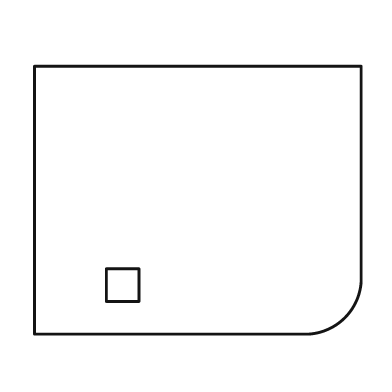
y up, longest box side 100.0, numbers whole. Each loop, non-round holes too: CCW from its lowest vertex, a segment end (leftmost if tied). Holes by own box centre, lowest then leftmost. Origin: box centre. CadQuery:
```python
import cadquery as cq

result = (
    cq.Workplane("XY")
    .moveTo(-50.0, -41.0)
    .lineTo(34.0, -41.0)
    .threePointArc((45.0, -36.0), (50.0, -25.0))
    .lineTo(50.0, 41.0)
    .lineTo(-50.0, 41.0)
    .close()
    .moveTo(-28.0, -31.0)
    .lineTo(-18.0, -31.0)
    .lineTo(-18.0, -21.0)
    .lineTo(-28.0, -21.0)
    .close()
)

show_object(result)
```